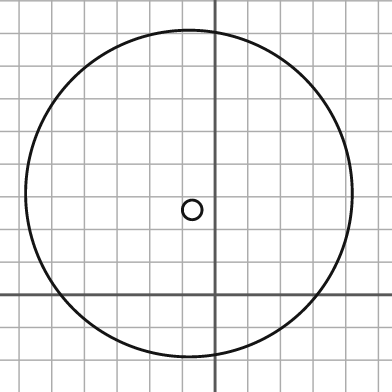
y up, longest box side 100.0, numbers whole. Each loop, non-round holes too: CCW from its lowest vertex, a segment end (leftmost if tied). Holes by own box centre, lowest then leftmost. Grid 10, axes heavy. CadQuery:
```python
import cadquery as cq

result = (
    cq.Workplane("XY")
    .moveTo(-8.0, 31.0)
    .circle(50.0)
    .moveTo(-7.0, 26.0)
    .circle(3.0)
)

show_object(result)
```